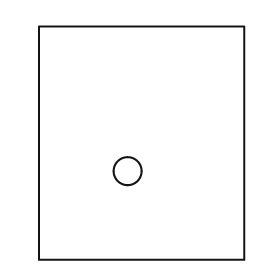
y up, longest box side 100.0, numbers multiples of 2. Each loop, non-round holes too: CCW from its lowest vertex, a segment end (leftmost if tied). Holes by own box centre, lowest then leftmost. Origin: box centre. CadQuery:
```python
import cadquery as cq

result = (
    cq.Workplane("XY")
    .moveTo(-44.0, -50.0)
    .lineTo(44.0, -50.0)
    .lineTo(44.0, 50.0)
    .lineTo(-44.0, 50.0)
    .close()
    .moveTo(-6.0, -12.0)
    .circle(6.0)
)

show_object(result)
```